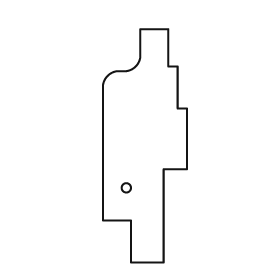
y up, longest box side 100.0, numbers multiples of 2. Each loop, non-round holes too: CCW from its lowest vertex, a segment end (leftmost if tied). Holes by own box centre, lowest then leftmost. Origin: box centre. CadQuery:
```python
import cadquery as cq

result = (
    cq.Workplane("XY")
    .moveTo(-6.0, -50.0)
    .lineTo(8.0, -50.0)
    .lineTo(8.0, -10.0)
    .lineTo(18.0, -10.0)
    .lineTo(18.0, 16.0)
    .lineTo(14.0, 16.0)
    .lineTo(14.0, 34.0)
    .lineTo(10.0, 34.0)
    .lineTo(10.0, 50.0)
    .lineTo(-2.0, 50.0)
    .lineTo(-2.0, 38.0)
    .threePointArc((-4.0, 34.0), (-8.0, 32.0))
    .lineTo(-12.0, 32.0)
    .threePointArc((-16.0, 30.0), (-18.0, 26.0))
    .lineTo(-18.0, -32.0)
    .lineTo(-6.0, -32.0)
    .close()
    .moveTo(-8.0, -18.0)
    .circle(2.0)
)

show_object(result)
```